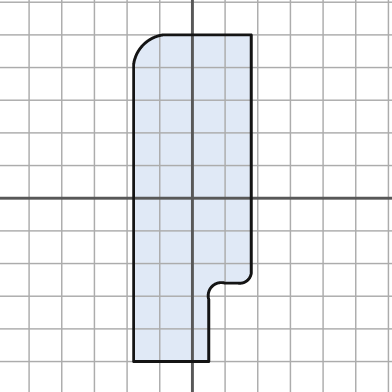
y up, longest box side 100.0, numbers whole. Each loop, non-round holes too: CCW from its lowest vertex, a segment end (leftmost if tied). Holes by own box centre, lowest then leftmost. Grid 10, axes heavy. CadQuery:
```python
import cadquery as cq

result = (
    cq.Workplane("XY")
    .moveTo(-18.0, -50.0)
    .lineTo(5.0, -50.0)
    .lineTo(5.0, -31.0)
    .threePointArc((6.0, -27.0), (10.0, -26.0))
    .lineTo(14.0, -26.0)
    .threePointArc((17.0, -25.0), (18.0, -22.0))
    .lineTo(18.0, 50.0)
    .lineTo(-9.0, 50.0)
    .threePointArc((-15.0, 47.0), (-18.0, 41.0))
    .close()
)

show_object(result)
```